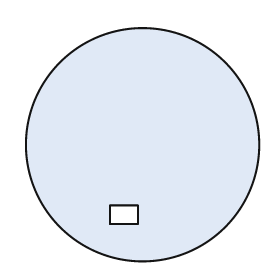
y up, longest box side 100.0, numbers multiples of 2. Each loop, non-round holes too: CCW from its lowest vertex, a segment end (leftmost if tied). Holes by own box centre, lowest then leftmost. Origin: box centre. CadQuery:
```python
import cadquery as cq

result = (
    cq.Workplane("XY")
    .moveTo(0.0, 0.0)
    .circle(50.0)
    .moveTo(-14.0, -34.0)
    .lineTo(-2.0, -34.0)
    .lineTo(-2.0, -26.0)
    .lineTo(-14.0, -26.0)
    .close()
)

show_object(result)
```